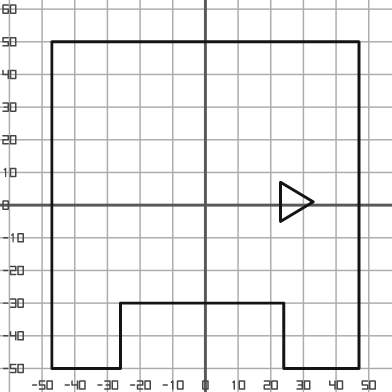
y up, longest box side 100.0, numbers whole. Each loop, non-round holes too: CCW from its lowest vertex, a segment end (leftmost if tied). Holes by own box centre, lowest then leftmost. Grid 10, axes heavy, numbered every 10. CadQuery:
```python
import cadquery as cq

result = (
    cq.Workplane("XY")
    .moveTo(-47.0, -50.0)
    .lineTo(-26.0, -50.0)
    .lineTo(-26.0, -30.0)
    .lineTo(24.0, -30.0)
    .lineTo(24.0, -50.0)
    .lineTo(47.0, -50.0)
    .lineTo(47.0, 50.0)
    .lineTo(-47.0, 50.0)
    .close()
    .moveTo(23.0, -5.0)
    .lineTo(33.0, 1.0)
    .lineTo(23.0, 7.0)
    .close()
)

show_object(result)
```